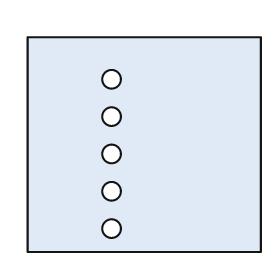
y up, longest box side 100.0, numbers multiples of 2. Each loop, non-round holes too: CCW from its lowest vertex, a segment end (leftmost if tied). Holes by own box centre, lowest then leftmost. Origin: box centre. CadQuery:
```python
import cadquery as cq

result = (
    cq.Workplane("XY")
    .moveTo(-50.0, -46.0)
    .lineTo(50.0, -46.0)
    .lineTo(50.0, 46.0)
    .lineTo(-50.0, 46.0)
    .close()
    .moveTo(-14.0, -36.0)
    .circle(4.0)
    .moveTo(-14.0, -20.0)
    .circle(4.0)
    .moveTo(-14.0, -4.0)
    .circle(4.0)
    .moveTo(-14.0, 12.0)
    .circle(4.0)
    .moveTo(-14.0, 28.0)
    .circle(4.0)
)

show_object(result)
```